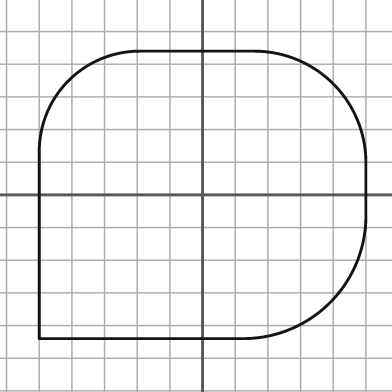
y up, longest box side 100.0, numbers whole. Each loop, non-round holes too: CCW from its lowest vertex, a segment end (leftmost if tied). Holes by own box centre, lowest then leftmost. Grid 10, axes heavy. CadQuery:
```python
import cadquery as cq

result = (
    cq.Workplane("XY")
    .moveTo(-50.0, -44.0)
    .lineTo(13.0, -44.0)
    .threePointArc((39.0, -33.0), (50.0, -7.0))
    .lineTo(50.0, 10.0)
    .threePointArc((40.0, 34.0), (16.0, 44.0))
    .lineTo(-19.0, 44.0)
    .threePointArc((-41.0, 35.0), (-50.0, 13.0))
    .close()
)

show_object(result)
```